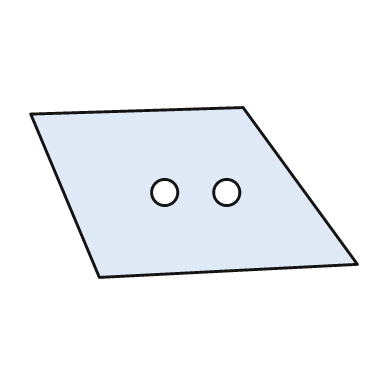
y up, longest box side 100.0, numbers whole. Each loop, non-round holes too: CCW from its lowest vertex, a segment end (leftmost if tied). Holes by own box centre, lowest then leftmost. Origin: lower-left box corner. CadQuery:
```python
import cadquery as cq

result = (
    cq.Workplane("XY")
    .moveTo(21.0, 0.0)
    .lineTo(100.0, 4.0)
    .lineTo(65.0, 52.0)
    .lineTo(0.0, 50.0)
    .close()
    .moveTo(41.0, 26.0)
    .circle(4.0)
    .moveTo(60.0, 26.0)
    .circle(4.0)
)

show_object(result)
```